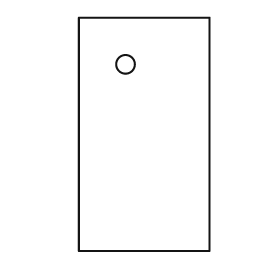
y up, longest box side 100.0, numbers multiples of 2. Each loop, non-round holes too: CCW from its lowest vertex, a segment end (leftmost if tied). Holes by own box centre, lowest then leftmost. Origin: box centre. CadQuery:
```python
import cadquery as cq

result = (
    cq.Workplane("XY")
    .moveTo(-28.0, -50.0)
    .lineTo(28.0, -50.0)
    .lineTo(28.0, 50.0)
    .lineTo(-28.0, 50.0)
    .close()
    .moveTo(-8.0, 30.0)
    .circle(4.0)
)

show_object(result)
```